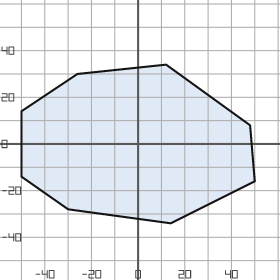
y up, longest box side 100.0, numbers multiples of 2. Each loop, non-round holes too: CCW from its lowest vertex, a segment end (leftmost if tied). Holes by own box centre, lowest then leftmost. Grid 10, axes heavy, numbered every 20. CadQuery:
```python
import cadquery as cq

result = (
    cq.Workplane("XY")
    .moveTo(14.0, -34.0)
    .lineTo(50.0, -16.0)
    .lineTo(48.0, 8.0)
    .lineTo(12.0, 34.0)
    .lineTo(-26.0, 30.0)
    .lineTo(-50.0, 14.0)
    .lineTo(-50.0, -14.0)
    .lineTo(-30.0, -28.0)
    .close()
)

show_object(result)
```